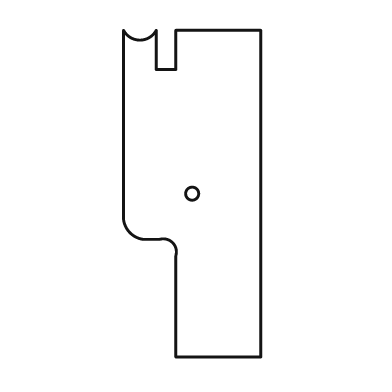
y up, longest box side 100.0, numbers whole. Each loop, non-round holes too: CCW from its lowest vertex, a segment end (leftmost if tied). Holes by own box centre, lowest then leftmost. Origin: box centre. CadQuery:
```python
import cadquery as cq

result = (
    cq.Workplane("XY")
    .moveTo(-5.0, -50.0)
    .lineTo(21.0, -50.0)
    .lineTo(21.0, 50.0)
    .lineTo(-5.0, 50.0)
    .lineTo(-5.0, 38.0)
    .lineTo(-11.0, 38.0)
    .lineTo(-11.0, 50.0)
    .threePointArc((-16.0, 47.0), (-21.0, 50.0))
    .lineTo(-21.0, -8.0)
    .threePointArc((-19.0, -12.0), (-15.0, -14.0))
    .lineTo(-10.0, -14.0)
    .threePointArc((-6.0, -15.0), (-5.0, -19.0))
    .close()
    .moveTo(0.0, 0.0)
    .circle(2.0)
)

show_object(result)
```